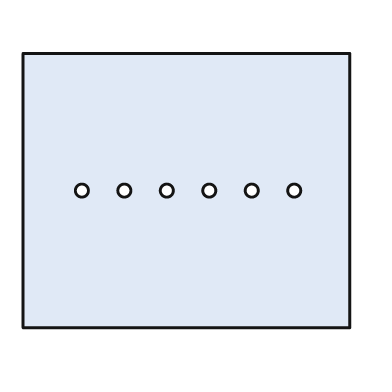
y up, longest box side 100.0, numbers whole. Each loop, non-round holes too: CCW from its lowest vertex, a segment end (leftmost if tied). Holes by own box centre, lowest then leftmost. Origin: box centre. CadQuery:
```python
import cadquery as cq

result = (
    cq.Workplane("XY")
    .moveTo(-50.0, -42.0)
    .lineTo(50.0, -42.0)
    .lineTo(50.0, 42.0)
    .lineTo(-50.0, 42.0)
    .close()
    .moveTo(-32.0, 0.0)
    .circle(2.0)
    .moveTo(-19.0, 0.0)
    .circle(2.0)
    .moveTo(-6.0, 0.0)
    .circle(2.0)
    .moveTo(7.0, 0.0)
    .circle(2.0)
    .moveTo(20.0, 0.0)
    .circle(2.0)
    .moveTo(33.0, 0.0)
    .circle(2.0)
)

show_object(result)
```